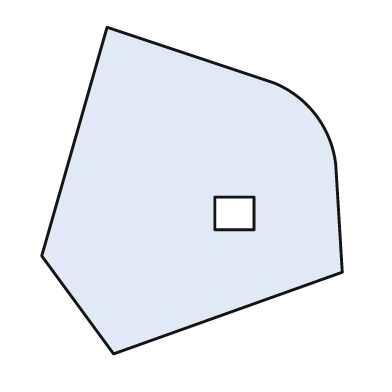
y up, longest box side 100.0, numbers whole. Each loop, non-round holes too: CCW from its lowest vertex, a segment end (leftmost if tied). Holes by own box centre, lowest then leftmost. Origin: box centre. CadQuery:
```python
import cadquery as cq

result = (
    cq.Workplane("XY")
    .moveTo(-24.0, -50.0)
    .lineTo(46.0, -25.0)
    .lineTo(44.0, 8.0)
    .threePointArc((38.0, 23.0), (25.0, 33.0))
    .lineTo(-26.0, 50.0)
    .lineTo(-46.0, -20.0)
    .close()
    .moveTo(7.0, -12.0)
    .lineTo(19.0, -12.0)
    .lineTo(19.0, -2.0)
    .lineTo(7.0, -2.0)
    .close()
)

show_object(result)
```